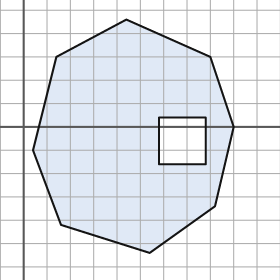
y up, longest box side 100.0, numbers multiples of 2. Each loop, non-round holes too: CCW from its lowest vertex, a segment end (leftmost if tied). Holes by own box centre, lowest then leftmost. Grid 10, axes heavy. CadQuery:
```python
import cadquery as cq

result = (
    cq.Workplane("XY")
    .moveTo(54.0, -54.0)
    .lineTo(82.0, -34.0)
    .lineTo(90.0, 0.0)
    .lineTo(80.0, 30.0)
    .lineTo(44.0, 46.0)
    .lineTo(14.0, 30.0)
    .lineTo(4.0, -10.0)
    .lineTo(16.0, -42.0)
    .close()
    .moveTo(58.0, -16.0)
    .lineTo(78.0, -16.0)
    .lineTo(78.0, 4.0)
    .lineTo(58.0, 4.0)
    .close()
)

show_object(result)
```